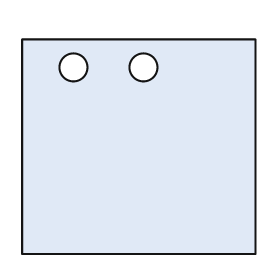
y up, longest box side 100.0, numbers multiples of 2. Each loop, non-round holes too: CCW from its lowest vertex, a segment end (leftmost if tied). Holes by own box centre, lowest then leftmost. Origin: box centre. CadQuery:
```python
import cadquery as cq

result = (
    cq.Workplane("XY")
    .moveTo(-50.0, -46.0)
    .lineTo(50.0, -46.0)
    .lineTo(50.0, 46.0)
    .lineTo(-50.0, 46.0)
    .close()
    .moveTo(-28.0, 34.0)
    .circle(6.0)
    .moveTo(2.0, 34.0)
    .circle(6.0)
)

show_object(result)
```